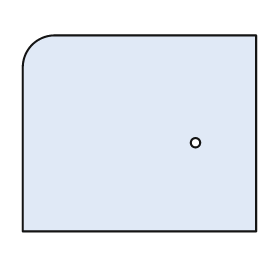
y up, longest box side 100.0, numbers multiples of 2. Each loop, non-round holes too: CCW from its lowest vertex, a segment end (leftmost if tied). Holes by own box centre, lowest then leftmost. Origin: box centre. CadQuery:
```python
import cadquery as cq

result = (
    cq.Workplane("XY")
    .moveTo(-50.0, -42.0)
    .lineTo(50.0, -42.0)
    .lineTo(50.0, 42.0)
    .lineTo(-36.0, 42.0)
    .threePointArc((-46.0, 38.0), (-50.0, 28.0))
    .close()
    .moveTo(24.0, -4.0)
    .circle(2.0)
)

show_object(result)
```